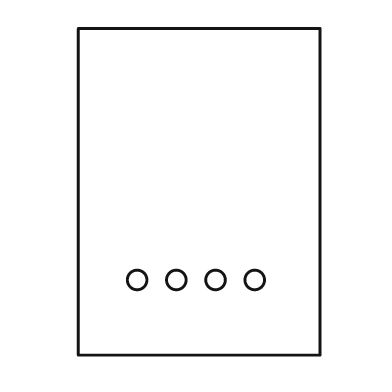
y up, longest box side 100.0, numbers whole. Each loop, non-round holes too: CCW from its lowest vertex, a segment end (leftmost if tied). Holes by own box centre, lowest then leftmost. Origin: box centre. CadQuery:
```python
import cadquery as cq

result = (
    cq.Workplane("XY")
    .moveTo(-37.0, -50.0)
    .lineTo(37.0, -50.0)
    .lineTo(37.0, 50.0)
    .lineTo(-37.0, 50.0)
    .close()
    .moveTo(-19.0, -27.0)
    .circle(3.0)
    .moveTo(-7.0, -27.0)
    .circle(3.0)
    .moveTo(5.0, -27.0)
    .circle(3.0)
    .moveTo(17.0, -27.0)
    .circle(3.0)
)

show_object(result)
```